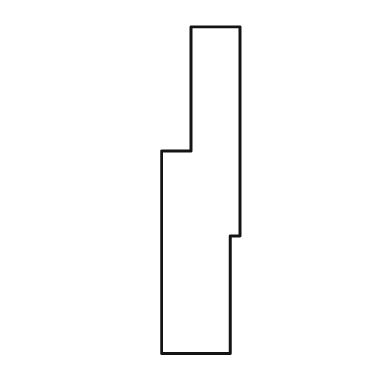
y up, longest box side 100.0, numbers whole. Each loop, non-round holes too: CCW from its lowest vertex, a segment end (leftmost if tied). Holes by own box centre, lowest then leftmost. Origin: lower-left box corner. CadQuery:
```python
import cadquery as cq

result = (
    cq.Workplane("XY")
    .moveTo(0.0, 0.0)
    .lineTo(21.0, 0.0)
    .lineTo(21.0, 36.0)
    .lineTo(24.0, 36.0)
    .lineTo(24.0, 100.0)
    .lineTo(9.0, 100.0)
    .lineTo(9.0, 62.0)
    .lineTo(0.0, 62.0)
    .close()
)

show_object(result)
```